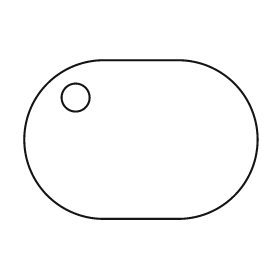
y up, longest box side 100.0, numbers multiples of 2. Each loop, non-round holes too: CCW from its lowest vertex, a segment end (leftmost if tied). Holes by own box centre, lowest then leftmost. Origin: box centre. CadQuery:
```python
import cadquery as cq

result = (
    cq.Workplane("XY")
    .moveTo(-16.0, -34.0)
    .lineTo(16.0, -34.0)
    .threePointArc((50.0, 0.0), (16.0, 34.0))
    .lineTo(-16.0, 34.0)
    .threePointArc((-50.0, 0.0), (-16.0, -34.0))
    .close()
    .moveTo(-28.0, 18.0)
    .circle(6.0)
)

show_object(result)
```